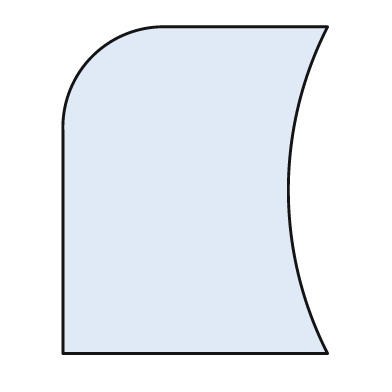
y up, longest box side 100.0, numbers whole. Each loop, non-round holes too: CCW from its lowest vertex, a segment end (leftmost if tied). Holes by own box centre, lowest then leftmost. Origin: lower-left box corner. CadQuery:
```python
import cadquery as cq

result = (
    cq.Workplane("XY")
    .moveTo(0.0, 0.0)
    .lineTo(81.0, 0.0)
    .threePointArc((69.0, 50.0), (81.0, 100.0))
    .lineTo(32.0, 100.0)
    .threePointArc((9.0, 91.0), (0.0, 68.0))
    .close()
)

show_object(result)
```